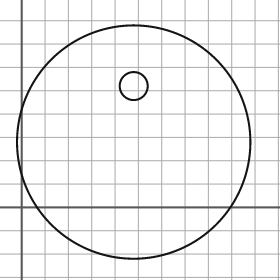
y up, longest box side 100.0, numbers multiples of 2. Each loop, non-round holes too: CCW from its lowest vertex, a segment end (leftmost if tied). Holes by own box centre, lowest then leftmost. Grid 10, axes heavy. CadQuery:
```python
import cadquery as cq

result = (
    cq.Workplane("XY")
    .moveTo(48.0, 28.0)
    .circle(50.0)
    .moveTo(48.0, 52.0)
    .circle(6.0)
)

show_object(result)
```